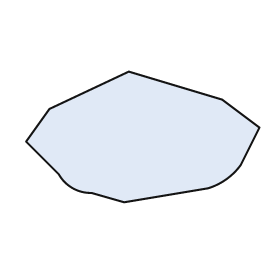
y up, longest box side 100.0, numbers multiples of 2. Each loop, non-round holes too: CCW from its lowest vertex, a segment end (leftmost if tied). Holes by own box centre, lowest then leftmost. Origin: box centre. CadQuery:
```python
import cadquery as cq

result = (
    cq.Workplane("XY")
    .moveTo(-8.0, -28.0)
    .lineTo(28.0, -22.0)
    .threePointArc((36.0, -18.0), (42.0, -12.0))
    .lineTo(50.0, 4.0)
    .lineTo(34.0, 16.0)
    .lineTo(-6.0, 28.0)
    .lineTo(-40.0, 12.0)
    .lineTo(-50.0, -2.0)
    .lineTo(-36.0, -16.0)
    .threePointArc((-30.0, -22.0), (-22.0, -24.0))
    .close()
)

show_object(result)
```